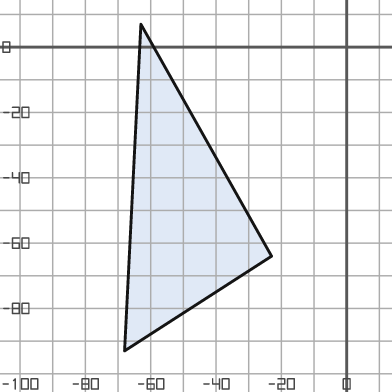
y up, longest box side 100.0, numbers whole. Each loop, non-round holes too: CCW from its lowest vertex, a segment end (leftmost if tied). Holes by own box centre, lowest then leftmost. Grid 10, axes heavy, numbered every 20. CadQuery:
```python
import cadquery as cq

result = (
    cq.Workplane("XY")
    .moveTo(-68.0, -93.0)
    .lineTo(-23.0, -64.0)
    .lineTo(-63.0, 7.0)
    .close()
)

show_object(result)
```